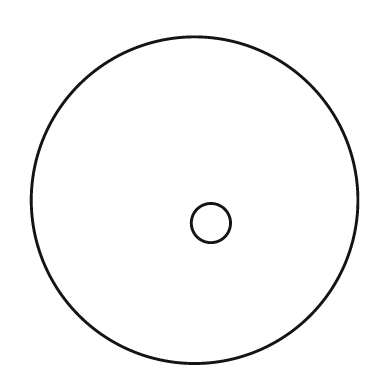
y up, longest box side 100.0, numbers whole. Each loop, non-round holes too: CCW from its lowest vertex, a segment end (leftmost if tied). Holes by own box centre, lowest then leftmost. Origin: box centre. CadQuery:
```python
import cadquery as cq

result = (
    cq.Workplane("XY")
    .moveTo(0.0, 0.0)
    .circle(50.0)
    .moveTo(5.0, -7.0)
    .circle(6.0)
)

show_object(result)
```